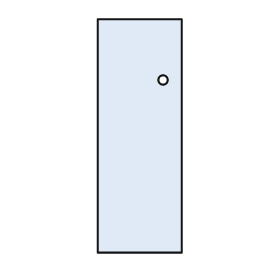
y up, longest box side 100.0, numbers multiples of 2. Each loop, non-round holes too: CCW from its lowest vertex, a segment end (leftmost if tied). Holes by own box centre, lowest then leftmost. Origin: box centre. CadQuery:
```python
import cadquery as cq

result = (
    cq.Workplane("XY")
    .moveTo(-18.0, -50.0)
    .lineTo(18.0, -50.0)
    .lineTo(18.0, 50.0)
    .lineTo(-18.0, 50.0)
    .close()
    .moveTo(10.0, 24.0)
    .circle(2.0)
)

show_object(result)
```